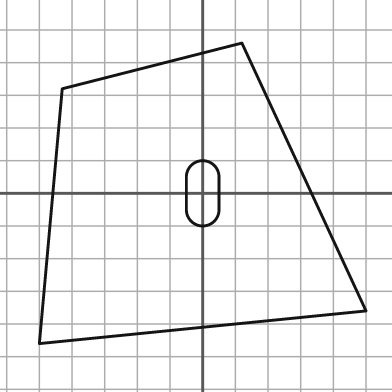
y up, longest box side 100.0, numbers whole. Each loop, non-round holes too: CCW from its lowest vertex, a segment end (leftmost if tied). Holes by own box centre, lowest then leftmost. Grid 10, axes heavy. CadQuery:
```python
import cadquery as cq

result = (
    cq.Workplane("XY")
    .moveTo(-50.0, -46.0)
    .lineTo(50.0, -36.0)
    .lineTo(12.0, 46.0)
    .lineTo(-43.0, 32.0)
    .close()
    .moveTo(-5.0, -5.0)
    .threePointArc((0.0, -10.0), (5.0, -5.0))
    .lineTo(5.0, 5.0)
    .threePointArc((0.0, 10.0), (-5.0, 5.0))
    .close()
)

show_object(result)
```